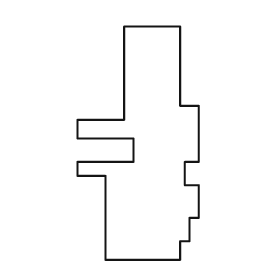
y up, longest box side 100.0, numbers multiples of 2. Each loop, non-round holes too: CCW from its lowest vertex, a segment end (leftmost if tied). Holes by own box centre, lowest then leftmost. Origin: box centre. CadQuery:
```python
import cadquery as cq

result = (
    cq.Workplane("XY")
    .moveTo(-14.0, -50.0)
    .lineTo(18.0, -50.0)
    .lineTo(18.0, -42.0)
    .lineTo(22.0, -42.0)
    .lineTo(22.0, -32.0)
    .lineTo(26.0, -32.0)
    .lineTo(26.0, -18.0)
    .lineTo(20.0, -18.0)
    .lineTo(20.0, -8.0)
    .lineTo(26.0, -8.0)
    .lineTo(26.0, 16.0)
    .lineTo(18.0, 16.0)
    .lineTo(18.0, 50.0)
    .lineTo(-6.0, 50.0)
    .lineTo(-6.0, 10.0)
    .lineTo(-26.0, 10.0)
    .lineTo(-26.0, 2.0)
    .lineTo(-2.0, 2.0)
    .lineTo(-2.0, -8.0)
    .lineTo(-26.0, -8.0)
    .lineTo(-26.0, -14.0)
    .lineTo(-14.0, -14.0)
    .close()
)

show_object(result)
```